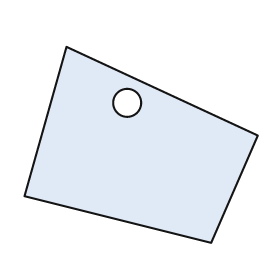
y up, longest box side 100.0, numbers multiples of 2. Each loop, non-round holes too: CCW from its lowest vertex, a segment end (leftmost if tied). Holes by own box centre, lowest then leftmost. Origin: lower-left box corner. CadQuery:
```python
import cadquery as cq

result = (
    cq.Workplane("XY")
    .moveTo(80.0, 0.0)
    .lineTo(100.0, 46.0)
    .lineTo(18.0, 84.0)
    .lineTo(0.0, 20.0)
    .close()
    .moveTo(44.0, 60.0)
    .circle(6.0)
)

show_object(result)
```